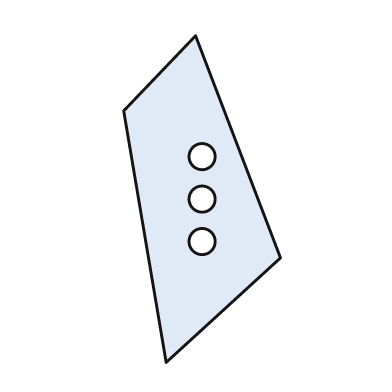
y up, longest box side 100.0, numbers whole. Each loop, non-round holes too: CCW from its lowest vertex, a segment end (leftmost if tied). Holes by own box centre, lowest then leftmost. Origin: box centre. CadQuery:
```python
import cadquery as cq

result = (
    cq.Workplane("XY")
    .moveTo(-11.0, -50.0)
    .lineTo(24.0, -18.0)
    .lineTo(-2.0, 50.0)
    .lineTo(-24.0, 27.0)
    .close()
    .moveTo(0.0, -13.0)
    .circle(4.0)
    .moveTo(0.0, 0.0)
    .circle(4.0)
    .moveTo(0.0, 13.0)
    .circle(4.0)
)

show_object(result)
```